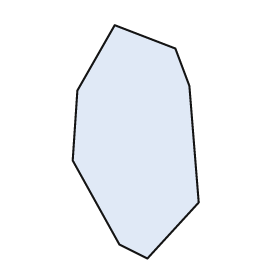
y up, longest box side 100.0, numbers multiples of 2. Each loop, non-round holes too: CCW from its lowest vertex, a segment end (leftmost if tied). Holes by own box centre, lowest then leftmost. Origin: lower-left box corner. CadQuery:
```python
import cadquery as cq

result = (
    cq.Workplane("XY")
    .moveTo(32.0, 0.0)
    .lineTo(54.0, 24.0)
    .lineTo(50.0, 74.0)
    .lineTo(44.0, 90.0)
    .lineTo(18.0, 100.0)
    .lineTo(2.0, 72.0)
    .lineTo(0.0, 42.0)
    .lineTo(20.0, 6.0)
    .close()
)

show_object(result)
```